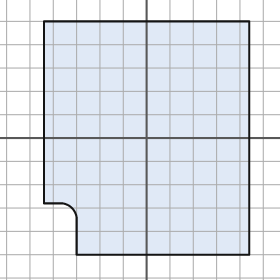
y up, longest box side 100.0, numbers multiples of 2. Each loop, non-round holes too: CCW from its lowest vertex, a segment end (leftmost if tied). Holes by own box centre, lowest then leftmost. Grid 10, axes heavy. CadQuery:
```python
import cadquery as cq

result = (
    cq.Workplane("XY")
    .moveTo(-30.0, -50.0)
    .lineTo(44.0, -50.0)
    .lineTo(44.0, 50.0)
    .lineTo(-44.0, 50.0)
    .lineTo(-44.0, -28.0)
    .lineTo(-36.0, -28.0)
    .threePointArc((-32.0, -30.0), (-30.0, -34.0))
    .close()
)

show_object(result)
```